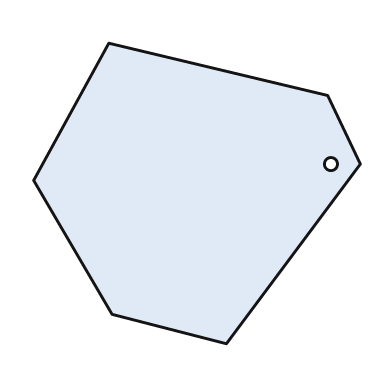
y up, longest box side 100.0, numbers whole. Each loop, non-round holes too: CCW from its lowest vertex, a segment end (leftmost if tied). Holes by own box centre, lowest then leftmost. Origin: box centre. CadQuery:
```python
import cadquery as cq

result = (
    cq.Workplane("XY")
    .moveTo(9.0, -46.0)
    .lineTo(50.0, 9.0)
    .lineTo(40.0, 30.0)
    .lineTo(-27.0, 46.0)
    .lineTo(-50.0, 4.0)
    .lineTo(-26.0, -37.0)
    .close()
    .moveTo(41.0, 9.0)
    .circle(2.0)
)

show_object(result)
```